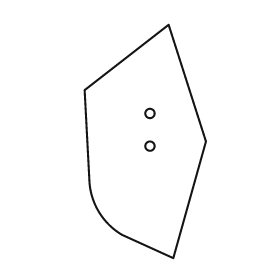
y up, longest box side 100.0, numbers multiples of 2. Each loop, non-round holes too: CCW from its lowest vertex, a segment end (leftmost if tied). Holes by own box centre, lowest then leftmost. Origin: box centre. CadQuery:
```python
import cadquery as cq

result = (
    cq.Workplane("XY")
    .moveTo(12.0, -50.0)
    .lineTo(26.0, 0.0)
    .lineTo(10.0, 50.0)
    .lineTo(-26.0, 22.0)
    .lineTo(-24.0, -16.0)
    .threePointArc((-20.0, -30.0), (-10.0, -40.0))
    .close()
    .moveTo(2.0, -2.0)
    .circle(2.0)
    .moveTo(2.0, 12.0)
    .circle(2.0)
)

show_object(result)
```